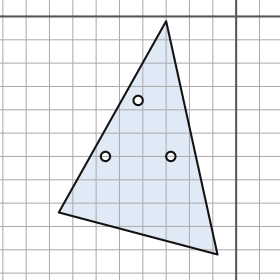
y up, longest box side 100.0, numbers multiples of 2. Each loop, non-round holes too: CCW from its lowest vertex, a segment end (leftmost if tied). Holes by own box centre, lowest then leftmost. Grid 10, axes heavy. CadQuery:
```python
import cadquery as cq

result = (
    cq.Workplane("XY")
    .moveTo(-8.0, -102.0)
    .lineTo(-30.0, -2.0)
    .lineTo(-76.0, -84.0)
    .close()
    .moveTo(-56.0, -60.0)
    .circle(2.0)
    .moveTo(-28.0, -60.0)
    .circle(2.0)
    .moveTo(-42.0, -36.0)
    .circle(2.0)
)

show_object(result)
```